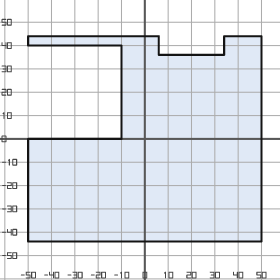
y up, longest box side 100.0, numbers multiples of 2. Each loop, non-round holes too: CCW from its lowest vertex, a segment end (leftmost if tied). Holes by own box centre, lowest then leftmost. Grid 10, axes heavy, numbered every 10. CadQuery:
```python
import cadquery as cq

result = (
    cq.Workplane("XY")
    .moveTo(-50.0, -44.0)
    .lineTo(50.0, -44.0)
    .lineTo(50.0, 44.0)
    .lineTo(34.0, 44.0)
    .lineTo(34.0, 36.0)
    .lineTo(6.0, 36.0)
    .lineTo(6.0, 44.0)
    .lineTo(-50.0, 44.0)
    .lineTo(-50.0, 40.0)
    .lineTo(-10.0, 40.0)
    .lineTo(-10.0, 0.0)
    .lineTo(-50.0, 0.0)
    .close()
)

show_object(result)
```